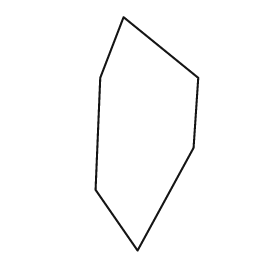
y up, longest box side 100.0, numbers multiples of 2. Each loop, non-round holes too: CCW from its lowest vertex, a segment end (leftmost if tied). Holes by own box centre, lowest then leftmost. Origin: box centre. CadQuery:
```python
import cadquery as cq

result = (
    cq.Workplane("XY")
    .moveTo(-4.0, -50.0)
    .lineTo(20.0, -6.0)
    .lineTo(22.0, 24.0)
    .lineTo(-10.0, 50.0)
    .lineTo(-20.0, 24.0)
    .lineTo(-22.0, -24.0)
    .close()
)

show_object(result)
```